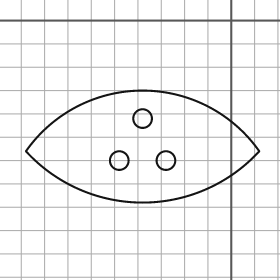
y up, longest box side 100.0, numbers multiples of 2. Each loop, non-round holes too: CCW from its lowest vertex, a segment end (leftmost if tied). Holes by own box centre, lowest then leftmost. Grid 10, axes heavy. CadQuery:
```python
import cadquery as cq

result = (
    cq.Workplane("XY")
    .moveTo(-88.0, -56.0)
    .threePointArc((-38.0, -78.0), (12.0, -56.0))
    .threePointArc((-38.0, -30.0), (-88.0, -56.0))
    .close()
    .moveTo(-48.0, -60.0)
    .circle(4.0)
    .moveTo(-28.0, -60.0)
    .circle(4.0)
    .moveTo(-38.0, -42.0)
    .circle(4.0)
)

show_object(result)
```